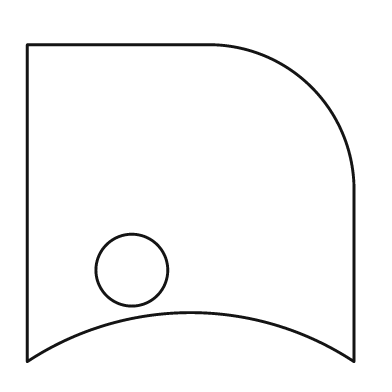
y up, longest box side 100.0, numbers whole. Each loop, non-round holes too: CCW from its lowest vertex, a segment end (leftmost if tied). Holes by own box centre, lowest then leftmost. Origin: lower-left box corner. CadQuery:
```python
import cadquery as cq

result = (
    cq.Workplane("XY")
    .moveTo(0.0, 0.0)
    .threePointArc((50.0, 15.0), (100.0, 0.0))
    .lineTo(100.0, 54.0)
    .threePointArc((87.0, 84.0), (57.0, 97.0))
    .lineTo(0.0, 97.0)
    .close()
    .moveTo(32.0, 28.0)
    .circle(11.0)
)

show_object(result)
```